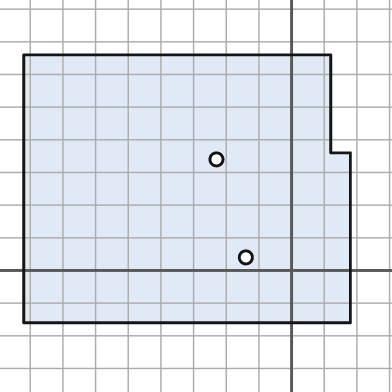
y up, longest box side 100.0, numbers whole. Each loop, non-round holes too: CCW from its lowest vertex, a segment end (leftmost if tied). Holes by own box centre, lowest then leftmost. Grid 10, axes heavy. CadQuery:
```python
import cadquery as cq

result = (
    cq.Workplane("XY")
    .moveTo(-82.0, -16.0)
    .lineTo(18.0, -16.0)
    .lineTo(18.0, 36.0)
    .lineTo(12.0, 36.0)
    .lineTo(12.0, 66.0)
    .lineTo(-82.0, 66.0)
    .close()
    .moveTo(-14.0, 4.0)
    .circle(2.0)
    .moveTo(-23.0, 34.0)
    .circle(2.0)
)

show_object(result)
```